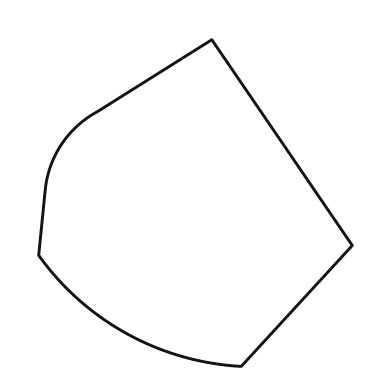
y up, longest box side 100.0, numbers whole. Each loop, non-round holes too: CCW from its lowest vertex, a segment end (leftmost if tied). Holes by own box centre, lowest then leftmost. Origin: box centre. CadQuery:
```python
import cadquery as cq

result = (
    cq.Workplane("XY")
    .moveTo(14.0, -50.0)
    .lineTo(48.0, -13.0)
    .lineTo(5.0, 50.0)
    .lineTo(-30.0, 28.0)
    .threePointArc((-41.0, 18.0), (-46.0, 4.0))
    .lineTo(-48.0, -16.0)
    .threePointArc((-21.0, -40.0), (14.0, -50.0))
    .close()
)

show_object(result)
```